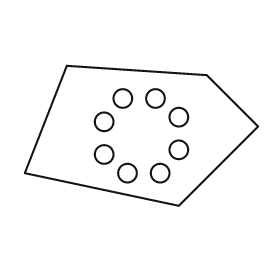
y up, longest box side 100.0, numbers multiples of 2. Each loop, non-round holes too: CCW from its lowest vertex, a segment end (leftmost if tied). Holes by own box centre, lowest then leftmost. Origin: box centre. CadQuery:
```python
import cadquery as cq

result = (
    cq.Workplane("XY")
    .moveTo(16.0, -30.0)
    .lineTo(50.0, 4.0)
    .lineTo(28.0, 26.0)
    .lineTo(-32.0, 30.0)
    .lineTo(-50.0, -16.0)
    .close()
    .moveTo(-6.0, -16.0)
    .circle(4.0)
    .moveTo(8.0, -16.0)
    .circle(4.0)
    .moveTo(-16.0, -8.0)
    .circle(4.0)
    .moveTo(16.0, -6.0)
    .circle(4.0)
    .moveTo(-16.0, 6.0)
    .circle(4.0)
    .moveTo(16.0, 8.0)
    .circle(4.0)
    .moveTo(-8.0, 16.0)
    .circle(4.0)
    .moveTo(6.0, 16.0)
    .circle(4.0)
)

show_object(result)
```